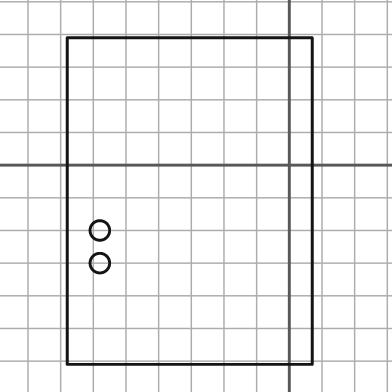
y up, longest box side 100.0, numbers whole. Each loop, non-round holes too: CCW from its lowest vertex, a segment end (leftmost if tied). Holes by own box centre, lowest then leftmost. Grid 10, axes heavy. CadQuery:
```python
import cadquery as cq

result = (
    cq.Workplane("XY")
    .moveTo(-68.0, -61.0)
    .lineTo(7.0, -61.0)
    .lineTo(7.0, 39.0)
    .lineTo(-68.0, 39.0)
    .close()
    .moveTo(-58.0, -30.0)
    .circle(3.0)
    .moveTo(-58.0, -20.0)
    .circle(3.0)
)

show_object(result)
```